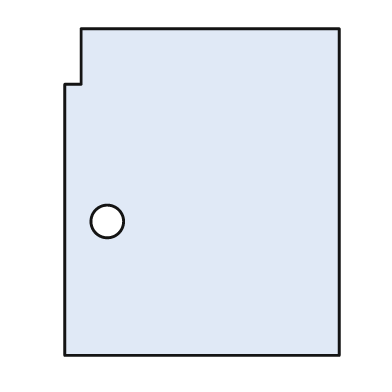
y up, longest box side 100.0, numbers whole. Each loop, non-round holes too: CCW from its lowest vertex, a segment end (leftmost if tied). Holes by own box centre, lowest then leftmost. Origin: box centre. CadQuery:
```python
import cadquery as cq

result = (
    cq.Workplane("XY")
    .moveTo(-42.0, -50.0)
    .lineTo(42.0, -50.0)
    .lineTo(42.0, 50.0)
    .lineTo(-37.0, 50.0)
    .lineTo(-37.0, 33.0)
    .lineTo(-42.0, 33.0)
    .close()
    .moveTo(-29.0, -9.0)
    .circle(5.0)
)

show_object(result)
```